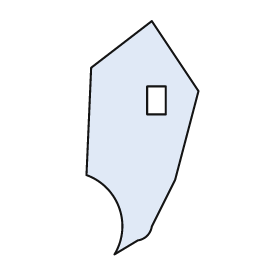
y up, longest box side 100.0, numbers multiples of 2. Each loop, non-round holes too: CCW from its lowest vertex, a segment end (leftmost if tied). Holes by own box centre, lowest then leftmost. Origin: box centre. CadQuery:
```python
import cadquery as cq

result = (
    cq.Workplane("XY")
    .moveTo(-12.0, -50.0)
    .lineTo(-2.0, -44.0)
    .threePointArc((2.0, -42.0), (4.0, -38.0))
    .lineTo(14.0, -18.0)
    .lineTo(24.0, 20.0)
    .lineTo(4.0, 50.0)
    .lineTo(-22.0, 30.0)
    .lineTo(-24.0, -16.0)
    .threePointArc((-10.0, -30.0), (-12.0, -50.0))
    .close()
    .moveTo(2.0, 10.0)
    .lineTo(10.0, 10.0)
    .lineTo(10.0, 22.0)
    .lineTo(2.0, 22.0)
    .close()
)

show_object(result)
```